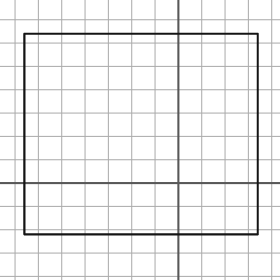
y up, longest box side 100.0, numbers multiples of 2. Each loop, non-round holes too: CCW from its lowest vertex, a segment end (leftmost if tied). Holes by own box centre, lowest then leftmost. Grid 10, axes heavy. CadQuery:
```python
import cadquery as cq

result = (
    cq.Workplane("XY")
    .moveTo(-66.0, -22.0)
    .lineTo(34.0, -22.0)
    .lineTo(34.0, 64.0)
    .lineTo(-66.0, 64.0)
    .close()
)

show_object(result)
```